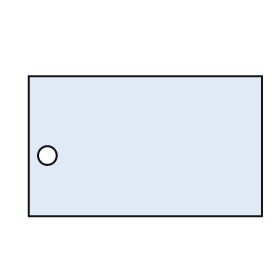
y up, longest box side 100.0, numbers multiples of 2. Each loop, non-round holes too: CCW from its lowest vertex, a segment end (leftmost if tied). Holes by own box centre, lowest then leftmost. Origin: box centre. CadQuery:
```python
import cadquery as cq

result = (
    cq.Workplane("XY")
    .moveTo(-50.0, -30.0)
    .lineTo(50.0, -30.0)
    .lineTo(50.0, 30.0)
    .lineTo(-50.0, 30.0)
    .close()
    .moveTo(-42.0, -4.0)
    .circle(4.0)
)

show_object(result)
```